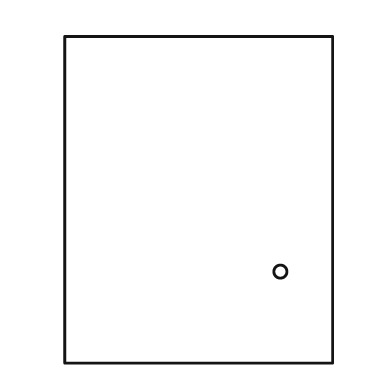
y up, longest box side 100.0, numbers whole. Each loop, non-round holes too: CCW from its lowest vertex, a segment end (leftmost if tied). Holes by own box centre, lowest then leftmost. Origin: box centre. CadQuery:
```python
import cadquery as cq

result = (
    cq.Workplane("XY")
    .moveTo(-41.0, -50.0)
    .lineTo(41.0, -50.0)
    .lineTo(41.0, 50.0)
    .lineTo(-41.0, 50.0)
    .close()
    .moveTo(25.0, -22.0)
    .circle(2.0)
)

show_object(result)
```